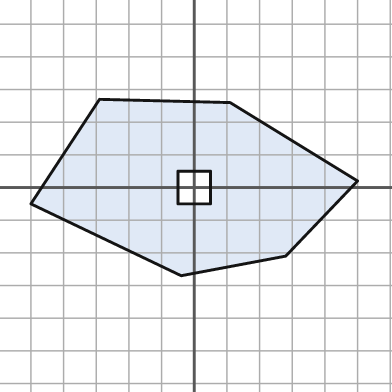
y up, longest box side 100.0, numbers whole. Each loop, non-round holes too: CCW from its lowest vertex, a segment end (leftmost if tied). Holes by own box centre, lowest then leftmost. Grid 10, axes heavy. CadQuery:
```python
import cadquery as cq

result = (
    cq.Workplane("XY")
    .moveTo(-4.0, -27.0)
    .lineTo(28.0, -21.0)
    .lineTo(50.0, 2.0)
    .lineTo(11.0, 26.0)
    .lineTo(-29.0, 27.0)
    .lineTo(-50.0, -5.0)
    .close()
    .moveTo(-5.0, -5.0)
    .lineTo(5.0, -5.0)
    .lineTo(5.0, 5.0)
    .lineTo(-5.0, 5.0)
    .close()
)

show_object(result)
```